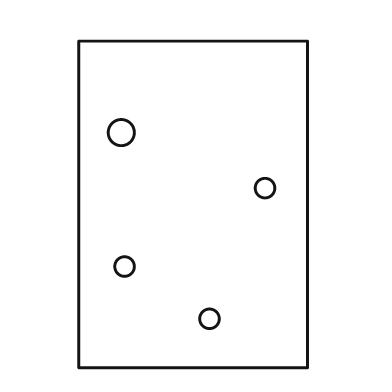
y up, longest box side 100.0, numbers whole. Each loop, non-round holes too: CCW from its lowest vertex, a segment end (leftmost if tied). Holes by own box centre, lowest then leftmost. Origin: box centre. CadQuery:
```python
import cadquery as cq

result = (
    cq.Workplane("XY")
    .moveTo(-35.0, -50.0)
    .lineTo(35.0, -50.0)
    .lineTo(35.0, 50.0)
    .lineTo(-35.0, 50.0)
    .close()
    .moveTo(5.0, -35.0)
    .circle(3.0)
    .moveTo(-21.0, -19.0)
    .circle(3.0)
    .moveTo(22.0, 5.0)
    .circle(3.0)
    .moveTo(-22.0, 22.0)
    .circle(4.0)
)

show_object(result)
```